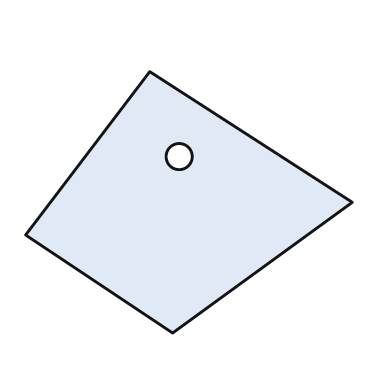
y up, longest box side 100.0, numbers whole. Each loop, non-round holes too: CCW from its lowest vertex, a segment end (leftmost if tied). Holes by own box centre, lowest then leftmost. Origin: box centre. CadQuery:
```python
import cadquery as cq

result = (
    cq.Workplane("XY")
    .moveTo(-5.0, -40.0)
    .lineTo(50.0, 0.0)
    .lineTo(-12.0, 40.0)
    .lineTo(-50.0, -10.0)
    .close()
    .moveTo(-3.0, 14.0)
    .circle(4.0)
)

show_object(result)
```